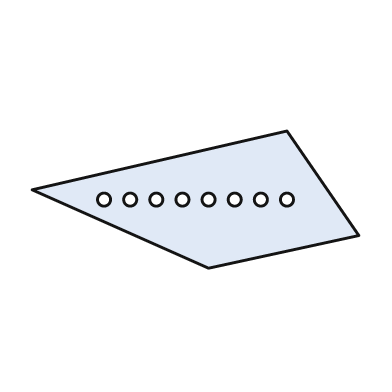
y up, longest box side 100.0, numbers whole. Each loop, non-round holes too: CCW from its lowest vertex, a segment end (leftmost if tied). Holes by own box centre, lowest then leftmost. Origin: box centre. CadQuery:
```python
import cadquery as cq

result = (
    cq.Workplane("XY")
    .moveTo(4.0, -21.0)
    .lineTo(50.0, -11.0)
    .lineTo(28.0, 21.0)
    .lineTo(-50.0, 3.0)
    .close()
    .moveTo(-28.0, 0.0)
    .circle(2.0)
    .moveTo(-20.0, 0.0)
    .circle(2.0)
    .moveTo(-12.0, 0.0)
    .circle(2.0)
    .moveTo(-4.0, 0.0)
    .circle(2.0)
    .moveTo(4.0, 0.0)
    .circle(2.0)
    .moveTo(12.0, 0.0)
    .circle(2.0)
    .moveTo(20.0, 0.0)
    .circle(2.0)
    .moveTo(28.0, 0.0)
    .circle(2.0)
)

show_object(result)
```